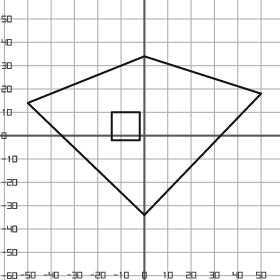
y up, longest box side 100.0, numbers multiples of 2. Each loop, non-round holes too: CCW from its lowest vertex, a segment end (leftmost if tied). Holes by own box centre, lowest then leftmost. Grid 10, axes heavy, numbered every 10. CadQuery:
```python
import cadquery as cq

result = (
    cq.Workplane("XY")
    .moveTo(0.0, -34.0)
    .lineTo(50.0, 18.0)
    .lineTo(0.0, 34.0)
    .lineTo(-50.0, 14.0)
    .close()
    .moveTo(-14.0, -2.0)
    .lineTo(-2.0, -2.0)
    .lineTo(-2.0, 10.0)
    .lineTo(-14.0, 10.0)
    .close()
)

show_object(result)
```